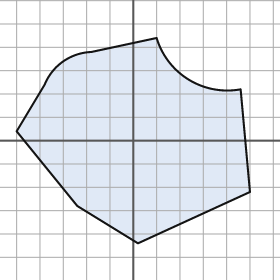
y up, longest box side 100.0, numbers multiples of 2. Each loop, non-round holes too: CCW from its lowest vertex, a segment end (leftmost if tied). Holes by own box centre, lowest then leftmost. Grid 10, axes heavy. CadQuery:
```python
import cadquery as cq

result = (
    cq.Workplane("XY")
    .moveTo(2.0, -44.0)
    .lineTo(50.0, -22.0)
    .lineTo(46.0, 22.0)
    .threePointArc((24.0, 26.0), (10.0, 44.0))
    .lineTo(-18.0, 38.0)
    .threePointArc((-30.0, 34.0), (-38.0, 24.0))
    .lineTo(-50.0, 4.0)
    .lineTo(-24.0, -28.0)
    .close()
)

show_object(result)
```